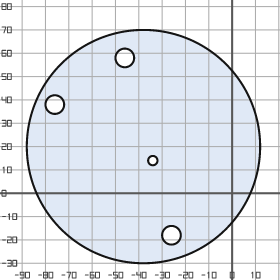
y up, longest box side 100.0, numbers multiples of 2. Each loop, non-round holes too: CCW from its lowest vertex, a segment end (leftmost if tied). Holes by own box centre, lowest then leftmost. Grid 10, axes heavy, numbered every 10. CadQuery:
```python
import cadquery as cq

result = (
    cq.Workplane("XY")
    .moveTo(-38.0, 20.0)
    .circle(50.0)
    .moveTo(-26.0, -18.0)
    .circle(4.0)
    .moveTo(-34.0, 14.0)
    .circle(2.0)
    .moveTo(-76.0, 38.0)
    .circle(4.0)
    .moveTo(-46.0, 58.0)
    .circle(4.0)
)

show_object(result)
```